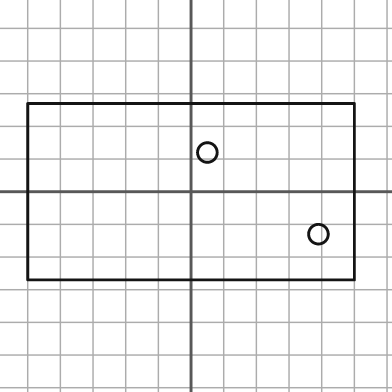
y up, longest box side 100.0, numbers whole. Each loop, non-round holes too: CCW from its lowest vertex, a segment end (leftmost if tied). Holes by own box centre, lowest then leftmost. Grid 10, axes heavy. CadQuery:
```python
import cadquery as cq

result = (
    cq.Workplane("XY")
    .moveTo(-50.0, -27.0)
    .lineTo(50.0, -27.0)
    .lineTo(50.0, 27.0)
    .lineTo(-50.0, 27.0)
    .close()
    .moveTo(39.0, -13.0)
    .circle(3.0)
    .moveTo(5.0, 12.0)
    .circle(3.0)
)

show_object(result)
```